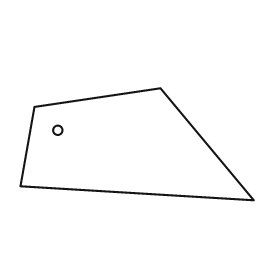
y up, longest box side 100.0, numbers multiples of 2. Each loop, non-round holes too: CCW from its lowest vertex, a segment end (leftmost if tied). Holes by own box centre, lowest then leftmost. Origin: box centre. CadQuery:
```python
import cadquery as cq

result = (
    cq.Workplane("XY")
    .moveTo(50.0, -24.0)
    .lineTo(10.0, 24.0)
    .lineTo(-44.0, 16.0)
    .lineTo(-50.0, -18.0)
    .close()
    .moveTo(-34.0, 6.0)
    .circle(2.0)
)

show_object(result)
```